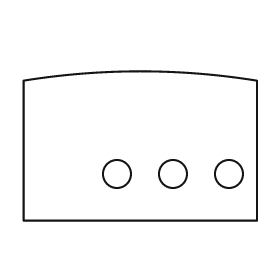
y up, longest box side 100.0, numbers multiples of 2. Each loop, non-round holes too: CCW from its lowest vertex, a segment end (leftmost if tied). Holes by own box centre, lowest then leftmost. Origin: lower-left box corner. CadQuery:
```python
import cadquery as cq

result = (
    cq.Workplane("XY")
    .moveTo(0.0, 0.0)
    .lineTo(100.0, 0.0)
    .lineTo(100.0, 60.0)
    .threePointArc((50.0, 64.0), (0.0, 60.0))
    .close()
    .moveTo(40.0, 20.0)
    .circle(6.0)
    .moveTo(64.0, 20.0)
    .circle(6.0)
    .moveTo(88.0, 20.0)
    .circle(6.0)
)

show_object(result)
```